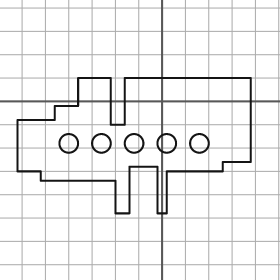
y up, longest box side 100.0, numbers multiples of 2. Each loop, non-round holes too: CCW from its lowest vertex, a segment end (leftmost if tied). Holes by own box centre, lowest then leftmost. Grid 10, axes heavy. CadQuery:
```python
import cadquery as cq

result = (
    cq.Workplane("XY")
    .moveTo(-20.0, -48.0)
    .lineTo(-14.0, -48.0)
    .lineTo(-14.0, -28.0)
    .lineTo(-2.0, -28.0)
    .lineTo(-2.0, -48.0)
    .lineTo(2.0, -48.0)
    .lineTo(2.0, -30.0)
    .lineTo(26.0, -30.0)
    .lineTo(26.0, -26.0)
    .lineTo(38.0, -26.0)
    .lineTo(38.0, 10.0)
    .lineTo(-16.0, 10.0)
    .lineTo(-16.0, -10.0)
    .lineTo(-22.0, -10.0)
    .lineTo(-22.0, 10.0)
    .lineTo(-36.0, 10.0)
    .lineTo(-36.0, -2.0)
    .lineTo(-46.0, -2.0)
    .lineTo(-46.0, -8.0)
    .lineTo(-62.0, -8.0)
    .lineTo(-62.0, -30.0)
    .lineTo(-52.0, -30.0)
    .lineTo(-52.0, -34.0)
    .lineTo(-20.0, -34.0)
    .close()
    .moveTo(-40.0, -18.0)
    .circle(4.0)
    .moveTo(-26.0, -18.0)
    .circle(4.0)
    .moveTo(-12.0, -18.0)
    .circle(4.0)
    .moveTo(2.0, -18.0)
    .circle(4.0)
    .moveTo(16.0, -18.0)
    .circle(4.0)
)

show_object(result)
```